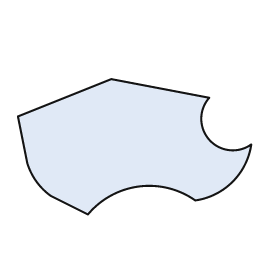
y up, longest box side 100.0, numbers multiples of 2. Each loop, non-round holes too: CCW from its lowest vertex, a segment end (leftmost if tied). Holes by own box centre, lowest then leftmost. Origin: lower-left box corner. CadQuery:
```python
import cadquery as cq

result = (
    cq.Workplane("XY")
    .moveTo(30.0, 0.0)
    .threePointArc((52.0, 12.0), (76.0, 6.0))
    .threePointArc((92.0, 14.0), (100.0, 30.0))
    .threePointArc((82.0, 32.0), (82.0, 50.0))
    .lineTo(40.0, 58.0)
    .lineTo(0.0, 42.0)
    .lineTo(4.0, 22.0)
    .threePointArc((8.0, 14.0), (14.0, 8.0))
    .close()
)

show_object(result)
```